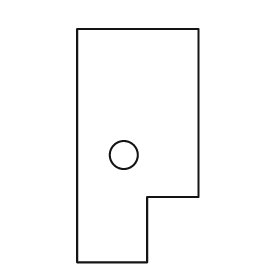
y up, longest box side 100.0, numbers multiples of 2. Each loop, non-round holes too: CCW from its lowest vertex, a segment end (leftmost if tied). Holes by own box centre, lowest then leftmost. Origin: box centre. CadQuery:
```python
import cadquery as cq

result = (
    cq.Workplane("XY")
    .moveTo(-26.0, -50.0)
    .lineTo(4.0, -50.0)
    .lineTo(4.0, -22.0)
    .lineTo(26.0, -22.0)
    .lineTo(26.0, 50.0)
    .lineTo(-26.0, 50.0)
    .close()
    .moveTo(-6.0, -4.0)
    .circle(6.0)
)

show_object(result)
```